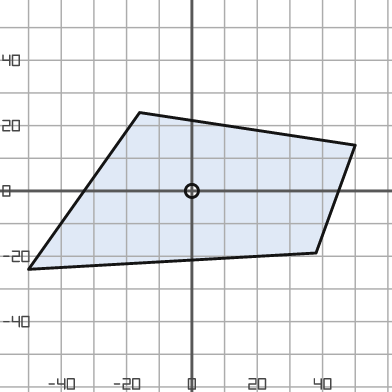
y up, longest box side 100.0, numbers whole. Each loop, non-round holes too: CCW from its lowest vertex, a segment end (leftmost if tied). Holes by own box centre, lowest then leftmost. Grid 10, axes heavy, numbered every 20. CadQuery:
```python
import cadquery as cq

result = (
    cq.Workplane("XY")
    .moveTo(-50.0, -24.0)
    .lineTo(38.0, -19.0)
    .lineTo(50.0, 14.0)
    .lineTo(-16.0, 24.0)
    .close()
    .moveTo(0.0, 0.0)
    .circle(2.0)
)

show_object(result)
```